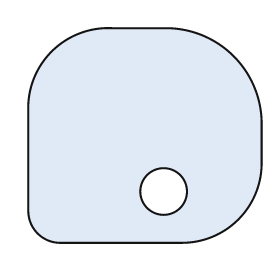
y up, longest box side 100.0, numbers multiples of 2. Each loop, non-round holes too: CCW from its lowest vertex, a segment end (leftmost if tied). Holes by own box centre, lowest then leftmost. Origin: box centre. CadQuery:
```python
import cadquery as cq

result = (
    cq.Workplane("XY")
    .moveTo(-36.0, -46.0)
    .lineTo(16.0, -46.0)
    .threePointArc((40.0, -36.0), (50.0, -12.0))
    .lineTo(50.0, 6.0)
    .threePointArc((38.0, 34.0), (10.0, 46.0))
    .lineTo(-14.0, 46.0)
    .threePointArc((-40.0, 36.0), (-50.0, 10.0))
    .lineTo(-50.0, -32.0)
    .threePointArc((-46.0, -42.0), (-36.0, -46.0))
    .close()
    .moveTo(8.0, -24.0)
    .circle(10.0)
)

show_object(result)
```